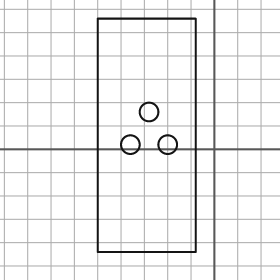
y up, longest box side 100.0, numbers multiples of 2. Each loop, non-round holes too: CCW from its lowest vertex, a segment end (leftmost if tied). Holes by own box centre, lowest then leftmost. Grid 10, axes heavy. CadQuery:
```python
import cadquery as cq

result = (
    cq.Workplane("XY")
    .moveTo(-50.0, -44.0)
    .lineTo(-8.0, -44.0)
    .lineTo(-8.0, 56.0)
    .lineTo(-50.0, 56.0)
    .close()
    .moveTo(-36.0, 2.0)
    .circle(4.0)
    .moveTo(-20.0, 2.0)
    .circle(4.0)
    .moveTo(-28.0, 16.0)
    .circle(4.0)
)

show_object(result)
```